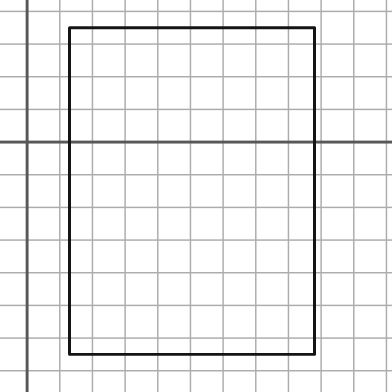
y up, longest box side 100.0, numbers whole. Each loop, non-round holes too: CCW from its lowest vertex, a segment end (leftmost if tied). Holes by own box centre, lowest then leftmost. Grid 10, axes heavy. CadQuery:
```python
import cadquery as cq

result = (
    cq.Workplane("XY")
    .moveTo(13.0, -65.0)
    .lineTo(88.0, -65.0)
    .lineTo(88.0, 35.0)
    .lineTo(13.0, 35.0)
    .close()
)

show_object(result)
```